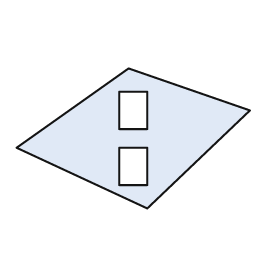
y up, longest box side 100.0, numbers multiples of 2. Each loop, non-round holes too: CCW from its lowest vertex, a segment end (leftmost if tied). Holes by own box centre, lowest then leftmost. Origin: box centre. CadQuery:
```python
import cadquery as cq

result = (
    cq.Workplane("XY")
    .moveTo(6.0, -30.0)
    .lineTo(50.0, 12.0)
    .lineTo(-2.0, 30.0)
    .lineTo(-50.0, -4.0)
    .close()
    .moveTo(-6.0, -20.0)
    .lineTo(6.0, -20.0)
    .lineTo(6.0, -4.0)
    .lineTo(-6.0, -4.0)
    .close()
    .moveTo(-6.0, 4.0)
    .lineTo(6.0, 4.0)
    .lineTo(6.0, 20.0)
    .lineTo(-6.0, 20.0)
    .close()
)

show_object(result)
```